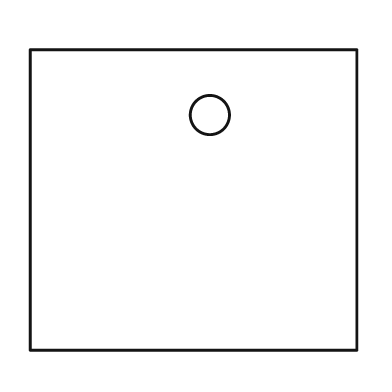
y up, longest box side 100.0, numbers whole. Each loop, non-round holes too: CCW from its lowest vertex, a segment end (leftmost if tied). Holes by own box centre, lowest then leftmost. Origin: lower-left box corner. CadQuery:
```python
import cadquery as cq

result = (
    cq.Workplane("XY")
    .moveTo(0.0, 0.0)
    .lineTo(100.0, 0.0)
    .lineTo(100.0, 92.0)
    .lineTo(0.0, 92.0)
    .close()
    .moveTo(55.0, 72.0)
    .circle(6.0)
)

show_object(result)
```